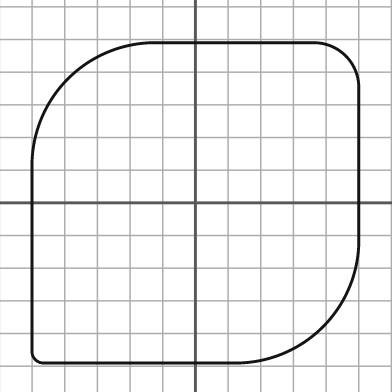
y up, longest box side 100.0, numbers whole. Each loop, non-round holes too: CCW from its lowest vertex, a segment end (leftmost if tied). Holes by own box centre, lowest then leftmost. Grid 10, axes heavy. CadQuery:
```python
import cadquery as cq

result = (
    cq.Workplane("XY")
    .moveTo(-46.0, -49.0)
    .lineTo(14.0, -49.0)
    .threePointArc((39.0, -38.0), (50.0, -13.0))
    .lineTo(50.0, 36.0)
    .threePointArc((46.0, 45.0), (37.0, 49.0))
    .lineTo(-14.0, 49.0)
    .threePointArc((-39.0, 38.0), (-50.0, 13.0))
    .lineTo(-50.0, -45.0)
    .threePointArc((-49.0, -48.0), (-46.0, -49.0))
    .close()
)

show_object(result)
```